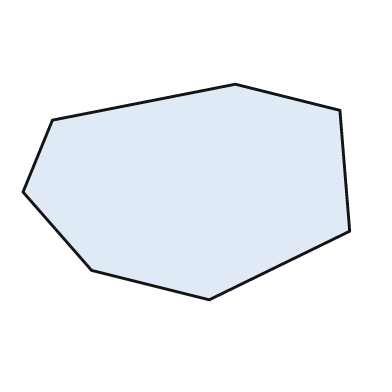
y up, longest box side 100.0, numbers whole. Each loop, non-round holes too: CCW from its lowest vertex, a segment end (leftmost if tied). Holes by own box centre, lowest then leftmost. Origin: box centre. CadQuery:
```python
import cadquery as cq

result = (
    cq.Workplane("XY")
    .moveTo(7.0, -33.0)
    .lineTo(50.0, -12.0)
    .lineTo(47.0, 25.0)
    .lineTo(15.0, 33.0)
    .lineTo(-41.0, 22.0)
    .lineTo(-50.0, 0.0)
    .lineTo(-29.0, -24.0)
    .close()
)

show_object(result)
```